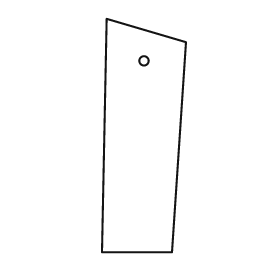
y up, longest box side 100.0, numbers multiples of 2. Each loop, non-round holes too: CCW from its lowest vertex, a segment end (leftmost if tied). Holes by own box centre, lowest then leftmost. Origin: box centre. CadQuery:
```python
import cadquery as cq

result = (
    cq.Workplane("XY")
    .moveTo(-18.0, -50.0)
    .lineTo(12.0, -50.0)
    .lineTo(18.0, 40.0)
    .lineTo(-16.0, 50.0)
    .close()
    .moveTo(0.0, 32.0)
    .circle(2.0)
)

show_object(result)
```